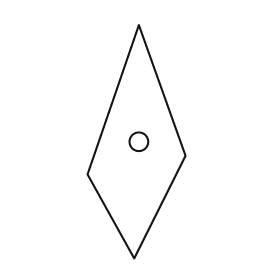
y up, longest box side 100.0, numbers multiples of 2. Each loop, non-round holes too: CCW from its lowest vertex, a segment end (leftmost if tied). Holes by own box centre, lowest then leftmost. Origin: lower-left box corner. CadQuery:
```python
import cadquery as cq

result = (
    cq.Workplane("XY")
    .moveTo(20.0, 0.0)
    .lineTo(42.0, 44.0)
    .lineTo(22.0, 100.0)
    .lineTo(0.0, 36.0)
    .close()
    .moveTo(22.0, 50.0)
    .circle(4.0)
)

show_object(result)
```